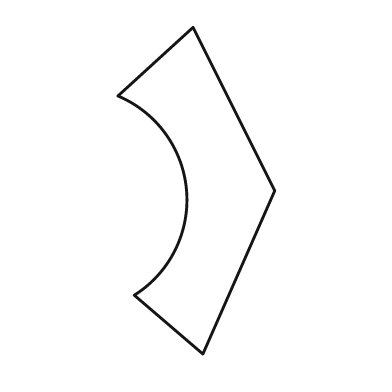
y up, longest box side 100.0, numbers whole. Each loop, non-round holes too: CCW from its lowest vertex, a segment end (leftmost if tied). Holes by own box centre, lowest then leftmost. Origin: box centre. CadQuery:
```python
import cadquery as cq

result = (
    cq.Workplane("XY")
    .moveTo(2.0, -50.0)
    .lineTo(24.0, 0.0)
    .lineTo(-1.0, 50.0)
    .lineTo(-24.0, 29.0)
    .threePointArc((-3.0, 0.0), (-19.0, -32.0))
    .close()
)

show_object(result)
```